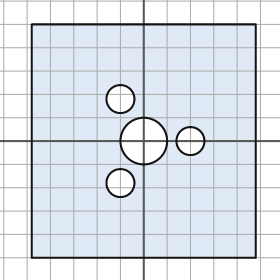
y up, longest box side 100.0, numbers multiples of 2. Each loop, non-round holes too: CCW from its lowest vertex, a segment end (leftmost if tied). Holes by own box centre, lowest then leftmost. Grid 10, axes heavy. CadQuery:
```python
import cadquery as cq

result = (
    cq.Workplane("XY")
    .moveTo(-48.0, -50.0)
    .lineTo(48.0, -50.0)
    .lineTo(48.0, 50.0)
    .lineTo(-48.0, 50.0)
    .close()
    .moveTo(-10.0, -18.0)
    .circle(6.0)
    .moveTo(0.0, 0.0)
    .circle(10.0)
    .moveTo(20.0, 0.0)
    .circle(6.0)
    .moveTo(-10.0, 18.0)
    .circle(6.0)
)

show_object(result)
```